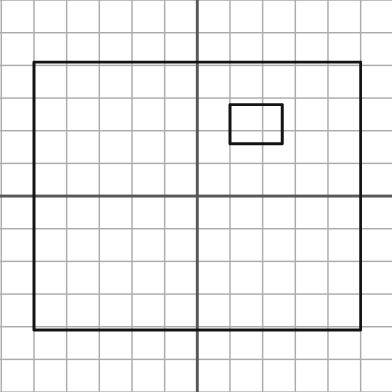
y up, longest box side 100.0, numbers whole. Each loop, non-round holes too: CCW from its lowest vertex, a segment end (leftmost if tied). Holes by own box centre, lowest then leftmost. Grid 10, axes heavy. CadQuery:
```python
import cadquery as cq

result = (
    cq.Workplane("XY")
    .moveTo(-50.0, -41.0)
    .lineTo(50.0, -41.0)
    .lineTo(50.0, 41.0)
    .lineTo(-50.0, 41.0)
    .close()
    .moveTo(10.0, 16.0)
    .lineTo(26.0, 16.0)
    .lineTo(26.0, 28.0)
    .lineTo(10.0, 28.0)
    .close()
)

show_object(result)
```